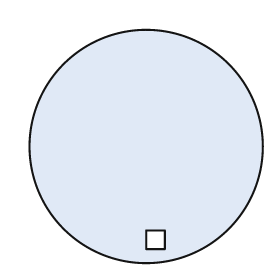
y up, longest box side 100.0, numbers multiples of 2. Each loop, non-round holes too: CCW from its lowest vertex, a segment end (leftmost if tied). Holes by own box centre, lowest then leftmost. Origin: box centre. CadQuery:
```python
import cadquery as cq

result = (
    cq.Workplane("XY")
    .moveTo(0.0, 0.0)
    .circle(50.0)
    .moveTo(0.0, -44.0)
    .lineTo(8.0, -44.0)
    .lineTo(8.0, -36.0)
    .lineTo(0.0, -36.0)
    .close()
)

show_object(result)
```